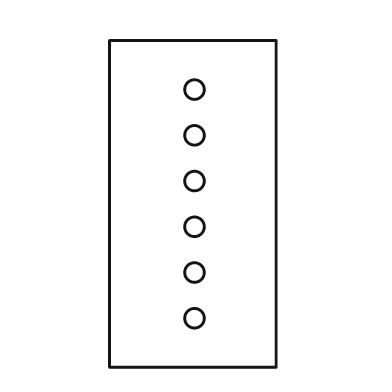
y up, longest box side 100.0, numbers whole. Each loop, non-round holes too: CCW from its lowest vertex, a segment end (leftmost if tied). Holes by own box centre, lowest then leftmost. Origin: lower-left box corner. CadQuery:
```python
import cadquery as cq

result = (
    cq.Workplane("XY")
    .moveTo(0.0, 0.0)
    .lineTo(51.0, 0.0)
    .lineTo(51.0, 100.0)
    .lineTo(0.0, 100.0)
    .close()
    .moveTo(26.0, 15.0)
    .circle(3.0)
    .moveTo(26.0, 29.0)
    .circle(3.0)
    .moveTo(26.0, 43.0)
    .circle(3.0)
    .moveTo(26.0, 57.0)
    .circle(3.0)
    .moveTo(26.0, 71.0)
    .circle(3.0)
    .moveTo(26.0, 85.0)
    .circle(3.0)
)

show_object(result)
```